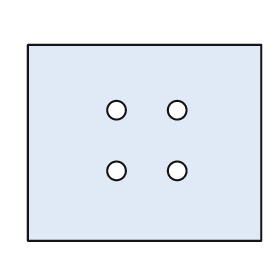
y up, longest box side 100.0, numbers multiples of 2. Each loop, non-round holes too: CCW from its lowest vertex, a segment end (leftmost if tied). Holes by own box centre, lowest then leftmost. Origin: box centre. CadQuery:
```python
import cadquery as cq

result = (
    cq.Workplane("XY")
    .moveTo(-50.0, -42.0)
    .lineTo(50.0, -42.0)
    .lineTo(50.0, 42.0)
    .lineTo(-50.0, 42.0)
    .close()
    .moveTo(-12.0, -12.0)
    .circle(4.0)
    .moveTo(14.0, -12.0)
    .circle(4.0)
    .moveTo(-12.0, 14.0)
    .circle(4.0)
    .moveTo(14.0, 14.0)
    .circle(4.0)
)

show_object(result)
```